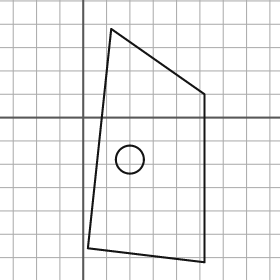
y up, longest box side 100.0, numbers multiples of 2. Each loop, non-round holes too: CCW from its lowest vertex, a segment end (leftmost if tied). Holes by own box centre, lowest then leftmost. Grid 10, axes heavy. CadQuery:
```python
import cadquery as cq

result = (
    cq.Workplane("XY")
    .moveTo(52.0, -62.0)
    .lineTo(52.0, 10.0)
    .lineTo(12.0, 38.0)
    .lineTo(2.0, -56.0)
    .close()
    .moveTo(20.0, -18.0)
    .circle(6.0)
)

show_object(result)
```